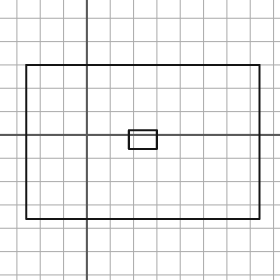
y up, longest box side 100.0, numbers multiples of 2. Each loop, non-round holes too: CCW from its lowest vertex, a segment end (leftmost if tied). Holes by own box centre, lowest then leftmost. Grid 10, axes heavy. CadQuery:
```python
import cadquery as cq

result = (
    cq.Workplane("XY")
    .moveTo(-26.0, -36.0)
    .lineTo(74.0, -36.0)
    .lineTo(74.0, 30.0)
    .lineTo(-26.0, 30.0)
    .close()
    .moveTo(18.0, -6.0)
    .lineTo(30.0, -6.0)
    .lineTo(30.0, 2.0)
    .lineTo(18.0, 2.0)
    .close()
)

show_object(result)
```